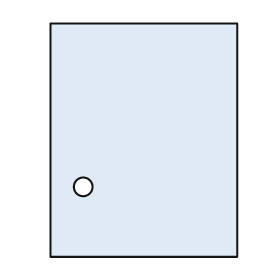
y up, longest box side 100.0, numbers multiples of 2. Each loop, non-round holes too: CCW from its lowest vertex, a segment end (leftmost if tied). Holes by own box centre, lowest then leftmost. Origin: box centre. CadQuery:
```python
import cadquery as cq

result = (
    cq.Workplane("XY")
    .moveTo(-40.0, -50.0)
    .lineTo(40.0, -50.0)
    .lineTo(40.0, 50.0)
    .lineTo(-40.0, 50.0)
    .close()
    .moveTo(-26.0, -20.0)
    .circle(4.0)
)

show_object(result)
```